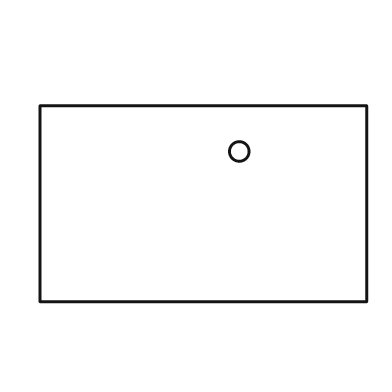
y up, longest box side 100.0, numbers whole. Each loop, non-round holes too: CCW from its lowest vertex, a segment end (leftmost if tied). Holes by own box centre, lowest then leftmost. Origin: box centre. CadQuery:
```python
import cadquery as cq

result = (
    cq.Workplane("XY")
    .moveTo(-50.0, -30.0)
    .lineTo(50.0, -30.0)
    .lineTo(50.0, 30.0)
    .lineTo(-50.0, 30.0)
    .close()
    .moveTo(11.0, 16.0)
    .circle(3.0)
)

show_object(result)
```